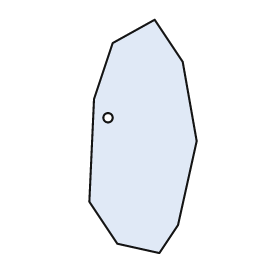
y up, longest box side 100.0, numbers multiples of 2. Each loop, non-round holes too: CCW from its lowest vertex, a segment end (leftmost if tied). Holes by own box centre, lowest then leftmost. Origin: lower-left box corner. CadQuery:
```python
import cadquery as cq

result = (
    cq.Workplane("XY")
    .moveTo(30.0, 0.0)
    .lineTo(38.0, 12.0)
    .lineTo(46.0, 48.0)
    .lineTo(40.0, 82.0)
    .lineTo(28.0, 100.0)
    .lineTo(10.0, 90.0)
    .lineTo(2.0, 66.0)
    .lineTo(0.0, 22.0)
    .lineTo(12.0, 4.0)
    .close()
    .moveTo(8.0, 58.0)
    .circle(2.0)
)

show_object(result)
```